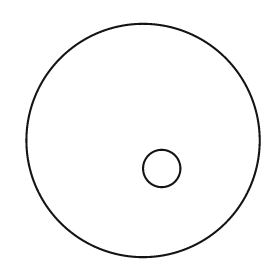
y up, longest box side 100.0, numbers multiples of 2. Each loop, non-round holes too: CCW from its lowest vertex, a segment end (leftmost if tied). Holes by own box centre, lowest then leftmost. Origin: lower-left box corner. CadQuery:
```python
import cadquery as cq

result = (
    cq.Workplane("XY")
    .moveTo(50.0, 50.0)
    .circle(50.0)
    .moveTo(58.0, 38.0)
    .circle(8.0)
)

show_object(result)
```